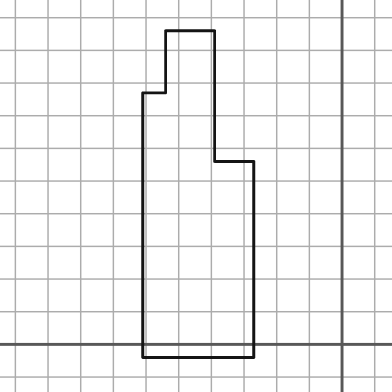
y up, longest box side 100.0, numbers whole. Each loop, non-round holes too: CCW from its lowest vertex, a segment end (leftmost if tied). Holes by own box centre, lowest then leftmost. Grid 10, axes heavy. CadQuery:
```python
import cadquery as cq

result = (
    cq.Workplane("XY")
    .moveTo(-61.0, -4.0)
    .lineTo(-27.0, -4.0)
    .lineTo(-27.0, 56.0)
    .lineTo(-39.0, 56.0)
    .lineTo(-39.0, 96.0)
    .lineTo(-54.0, 96.0)
    .lineTo(-54.0, 77.0)
    .lineTo(-61.0, 77.0)
    .close()
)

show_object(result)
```